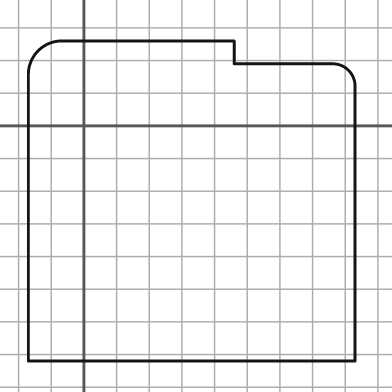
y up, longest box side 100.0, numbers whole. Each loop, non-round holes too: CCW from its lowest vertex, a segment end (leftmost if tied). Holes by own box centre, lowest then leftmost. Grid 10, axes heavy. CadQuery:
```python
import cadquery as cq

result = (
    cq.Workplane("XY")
    .moveTo(-17.0, -72.0)
    .lineTo(83.0, -72.0)
    .lineTo(83.0, 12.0)
    .threePointArc((81.0, 17.0), (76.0, 19.0))
    .lineTo(46.0, 19.0)
    .lineTo(46.0, 26.0)
    .lineTo(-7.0, 26.0)
    .threePointArc((-14.0, 23.0), (-17.0, 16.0))
    .close()
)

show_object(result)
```